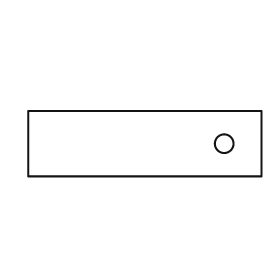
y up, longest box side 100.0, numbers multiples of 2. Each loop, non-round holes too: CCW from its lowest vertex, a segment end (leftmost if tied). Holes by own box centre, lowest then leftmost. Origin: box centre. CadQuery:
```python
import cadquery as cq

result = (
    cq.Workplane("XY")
    .moveTo(-50.0, -14.0)
    .lineTo(50.0, -14.0)
    .lineTo(50.0, 14.0)
    .lineTo(-50.0, 14.0)
    .close()
    .moveTo(34.0, 0.0)
    .circle(4.0)
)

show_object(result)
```